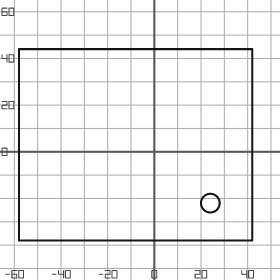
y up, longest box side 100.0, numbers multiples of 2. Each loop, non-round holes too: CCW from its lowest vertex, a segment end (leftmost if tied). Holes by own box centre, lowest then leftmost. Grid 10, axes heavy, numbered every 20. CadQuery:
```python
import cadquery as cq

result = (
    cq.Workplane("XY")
    .moveTo(-58.0, -38.0)
    .lineTo(42.0, -38.0)
    .lineTo(42.0, 44.0)
    .lineTo(-58.0, 44.0)
    .close()
    .moveTo(24.0, -22.0)
    .circle(4.0)
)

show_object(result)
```